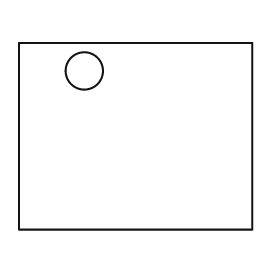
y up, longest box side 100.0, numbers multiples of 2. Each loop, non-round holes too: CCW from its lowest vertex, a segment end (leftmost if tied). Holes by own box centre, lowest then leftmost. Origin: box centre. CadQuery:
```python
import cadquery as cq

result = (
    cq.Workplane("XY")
    .moveTo(-50.0, -40.0)
    .lineTo(50.0, -40.0)
    .lineTo(50.0, 40.0)
    .lineTo(-50.0, 40.0)
    .close()
    .moveTo(-22.0, 28.0)
    .circle(8.0)
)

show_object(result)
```